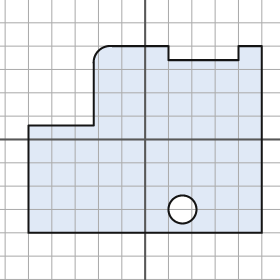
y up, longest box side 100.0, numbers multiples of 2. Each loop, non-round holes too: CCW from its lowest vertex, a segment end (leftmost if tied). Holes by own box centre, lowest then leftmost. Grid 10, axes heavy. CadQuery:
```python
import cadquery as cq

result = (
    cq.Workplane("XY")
    .moveTo(-50.0, -40.0)
    .lineTo(50.0, -40.0)
    .lineTo(50.0, 40.0)
    .lineTo(40.0, 40.0)
    .lineTo(40.0, 34.0)
    .lineTo(10.0, 34.0)
    .lineTo(10.0, 40.0)
    .lineTo(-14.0, 40.0)
    .threePointArc((-20.0, 38.0), (-22.0, 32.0))
    .lineTo(-22.0, 6.0)
    .lineTo(-50.0, 6.0)
    .close()
    .moveTo(16.0, -30.0)
    .circle(6.0)
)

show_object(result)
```